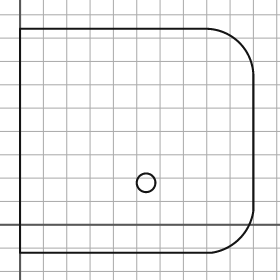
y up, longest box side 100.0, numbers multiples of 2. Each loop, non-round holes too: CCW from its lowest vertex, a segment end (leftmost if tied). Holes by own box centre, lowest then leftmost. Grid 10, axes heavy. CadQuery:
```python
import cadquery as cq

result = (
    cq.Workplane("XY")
    .moveTo(0.0, -12.0)
    .lineTo(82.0, -12.0)
    .threePointArc((94.0, -6.0), (100.0, 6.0))
    .lineTo(100.0, 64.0)
    .threePointArc((94.0, 78.0), (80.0, 84.0))
    .lineTo(0.0, 84.0)
    .close()
    .moveTo(54.0, 18.0)
    .circle(4.0)
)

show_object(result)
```